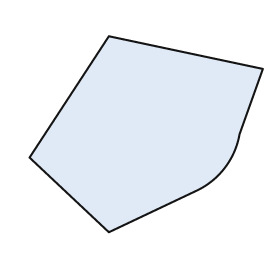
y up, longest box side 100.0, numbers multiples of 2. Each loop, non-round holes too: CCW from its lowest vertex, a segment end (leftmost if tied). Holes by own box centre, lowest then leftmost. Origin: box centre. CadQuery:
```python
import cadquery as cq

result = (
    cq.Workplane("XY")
    .moveTo(-16.0, -42.0)
    .lineTo(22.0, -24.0)
    .threePointArc((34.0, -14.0), (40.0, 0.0))
    .lineTo(50.0, 28.0)
    .lineTo(-16.0, 42.0)
    .lineTo(-50.0, -10.0)
    .close()
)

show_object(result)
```